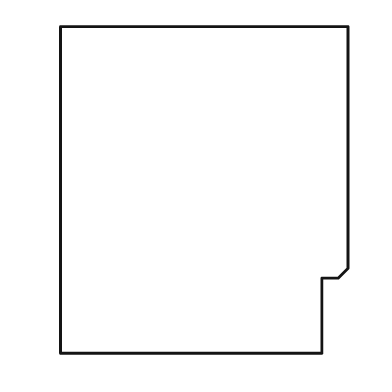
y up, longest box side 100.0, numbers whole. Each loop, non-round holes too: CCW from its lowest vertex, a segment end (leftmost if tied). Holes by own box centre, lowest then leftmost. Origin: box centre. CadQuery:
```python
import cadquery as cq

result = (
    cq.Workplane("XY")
    .moveTo(-44.0, -50.0)
    .lineTo(36.0, -50.0)
    .lineTo(36.0, -27.0)
    .lineTo(41.0, -27.0)
    .lineTo(44.0, -24.0)
    .lineTo(44.0, 50.0)
    .lineTo(-44.0, 50.0)
    .close()
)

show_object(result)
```